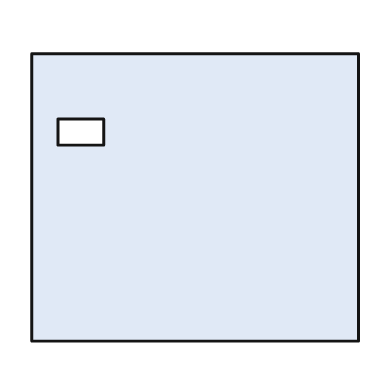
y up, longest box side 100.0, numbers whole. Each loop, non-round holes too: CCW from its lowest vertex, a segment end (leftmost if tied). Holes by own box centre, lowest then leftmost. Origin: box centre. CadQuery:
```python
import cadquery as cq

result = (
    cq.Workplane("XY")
    .moveTo(-50.0, -44.0)
    .lineTo(50.0, -44.0)
    .lineTo(50.0, 44.0)
    .lineTo(-50.0, 44.0)
    .close()
    .moveTo(-42.0, 16.0)
    .lineTo(-28.0, 16.0)
    .lineTo(-28.0, 24.0)
    .lineTo(-42.0, 24.0)
    .close()
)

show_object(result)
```